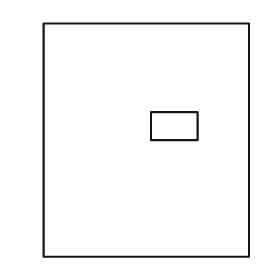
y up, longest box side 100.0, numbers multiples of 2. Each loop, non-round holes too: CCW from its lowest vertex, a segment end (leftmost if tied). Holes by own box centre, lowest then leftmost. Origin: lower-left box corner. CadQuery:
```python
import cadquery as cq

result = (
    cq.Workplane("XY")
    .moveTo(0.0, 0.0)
    .lineTo(88.0, 0.0)
    .lineTo(88.0, 100.0)
    .lineTo(0.0, 100.0)
    .close()
    .moveTo(46.0, 50.0)
    .lineTo(66.0, 50.0)
    .lineTo(66.0, 62.0)
    .lineTo(46.0, 62.0)
    .close()
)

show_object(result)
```